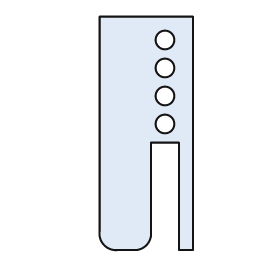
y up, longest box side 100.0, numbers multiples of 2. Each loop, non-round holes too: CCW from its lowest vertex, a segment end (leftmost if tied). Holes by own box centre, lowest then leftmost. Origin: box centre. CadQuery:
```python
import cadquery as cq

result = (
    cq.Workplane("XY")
    .moveTo(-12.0, -50.0)
    .lineTo(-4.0, -50.0)
    .threePointArc((0.0, -48.0), (2.0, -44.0))
    .lineTo(2.0, -4.0)
    .lineTo(14.0, -4.0)
    .lineTo(14.0, -50.0)
    .lineTo(20.0, -50.0)
    .lineTo(20.0, 50.0)
    .lineTo(-20.0, 50.0)
    .lineTo(-20.0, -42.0)
    .threePointArc((-18.0, -48.0), (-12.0, -50.0))
    .close()
    .moveTo(8.0, 4.0)
    .circle(4.0)
    .moveTo(8.0, 16.0)
    .circle(4.0)
    .moveTo(8.0, 28.0)
    .circle(4.0)
    .moveTo(8.0, 40.0)
    .circle(4.0)
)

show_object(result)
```